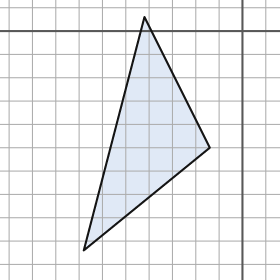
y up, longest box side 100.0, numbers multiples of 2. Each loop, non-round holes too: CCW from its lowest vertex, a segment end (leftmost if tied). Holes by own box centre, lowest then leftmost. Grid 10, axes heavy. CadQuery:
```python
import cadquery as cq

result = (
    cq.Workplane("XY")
    .moveTo(-68.0, -94.0)
    .lineTo(-14.0, -50.0)
    .lineTo(-42.0, 6.0)
    .close()
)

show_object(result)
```